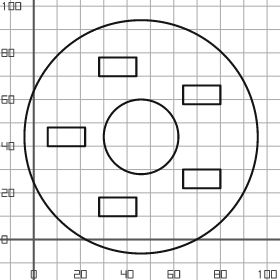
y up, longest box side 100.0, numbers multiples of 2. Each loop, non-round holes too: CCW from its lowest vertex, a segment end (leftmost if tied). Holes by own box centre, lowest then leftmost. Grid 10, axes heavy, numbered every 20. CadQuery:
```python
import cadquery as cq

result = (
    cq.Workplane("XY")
    .moveTo(46.0, 44.0)
    .circle(50.0)
    .moveTo(28.0, 10.0)
    .lineTo(44.0, 10.0)
    .lineTo(44.0, 18.0)
    .lineTo(28.0, 18.0)
    .close()
    .moveTo(64.0, 22.0)
    .lineTo(80.0, 22.0)
    .lineTo(80.0, 30.0)
    .lineTo(64.0, 30.0)
    .close()
    .moveTo(6.0, 40.0)
    .lineTo(22.0, 40.0)
    .lineTo(22.0, 48.0)
    .lineTo(6.0, 48.0)
    .close()
    .moveTo(46.0, 44.0)
    .circle(16.0)
    .moveTo(64.0, 58.0)
    .lineTo(80.0, 58.0)
    .lineTo(80.0, 66.0)
    .lineTo(64.0, 66.0)
    .close()
    .moveTo(28.0, 70.0)
    .lineTo(44.0, 70.0)
    .lineTo(44.0, 78.0)
    .lineTo(28.0, 78.0)
    .close()
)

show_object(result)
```